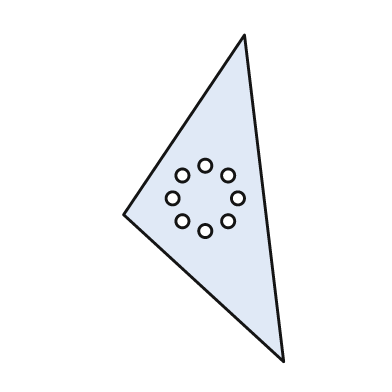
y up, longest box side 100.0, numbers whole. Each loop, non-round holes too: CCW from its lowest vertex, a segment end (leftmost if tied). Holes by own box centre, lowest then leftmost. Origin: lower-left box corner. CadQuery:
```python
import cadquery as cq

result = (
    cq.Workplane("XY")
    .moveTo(49.0, 0.0)
    .lineTo(37.0, 100.0)
    .lineTo(0.0, 45.0)
    .close()
    .moveTo(25.0, 40.0)
    .circle(2.0)
    .moveTo(18.0, 43.0)
    .circle(2.0)
    .moveTo(32.0, 43.0)
    .circle(2.0)
    .moveTo(15.0, 50.0)
    .circle(2.0)
    .moveTo(35.0, 50.0)
    .circle(2.0)
    .moveTo(18.0, 57.0)
    .circle(2.0)
    .moveTo(32.0, 57.0)
    .circle(2.0)
    .moveTo(25.0, 60.0)
    .circle(2.0)
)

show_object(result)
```